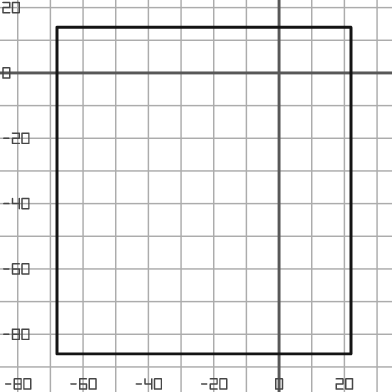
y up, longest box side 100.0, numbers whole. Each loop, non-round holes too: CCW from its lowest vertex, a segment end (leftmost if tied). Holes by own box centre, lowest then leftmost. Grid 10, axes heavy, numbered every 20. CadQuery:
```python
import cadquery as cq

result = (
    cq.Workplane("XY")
    .moveTo(-68.0, -86.0)
    .lineTo(22.0, -86.0)
    .lineTo(22.0, 14.0)
    .lineTo(-68.0, 14.0)
    .close()
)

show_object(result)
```